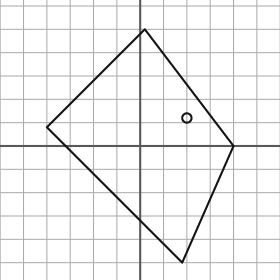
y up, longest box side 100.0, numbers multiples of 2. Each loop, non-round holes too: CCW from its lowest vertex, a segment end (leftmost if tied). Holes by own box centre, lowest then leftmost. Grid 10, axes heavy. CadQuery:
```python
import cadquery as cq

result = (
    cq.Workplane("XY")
    .moveTo(18.0, -50.0)
    .lineTo(40.0, 0.0)
    .lineTo(2.0, 50.0)
    .lineTo(-40.0, 8.0)
    .close()
    .moveTo(20.0, 12.0)
    .circle(2.0)
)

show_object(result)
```